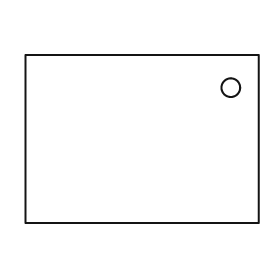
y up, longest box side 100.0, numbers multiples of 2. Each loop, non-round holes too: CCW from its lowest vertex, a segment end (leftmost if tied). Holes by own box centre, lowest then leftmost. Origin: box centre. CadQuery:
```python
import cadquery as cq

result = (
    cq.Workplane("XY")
    .moveTo(-50.0, -36.0)
    .lineTo(50.0, -36.0)
    .lineTo(50.0, 36.0)
    .lineTo(-50.0, 36.0)
    .close()
    .moveTo(38.0, 22.0)
    .circle(4.0)
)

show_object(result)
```